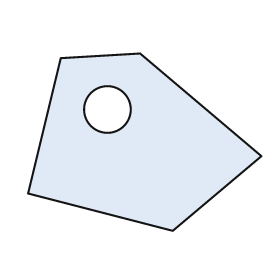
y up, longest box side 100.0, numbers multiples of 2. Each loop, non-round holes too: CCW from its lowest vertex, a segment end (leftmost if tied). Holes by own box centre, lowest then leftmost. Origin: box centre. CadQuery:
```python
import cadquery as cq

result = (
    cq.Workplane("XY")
    .moveTo(12.0, -38.0)
    .lineTo(50.0, -6.0)
    .lineTo(-2.0, 38.0)
    .lineTo(-36.0, 36.0)
    .lineTo(-50.0, -22.0)
    .close()
    .moveTo(-16.0, 14.0)
    .circle(10.0)
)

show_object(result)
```